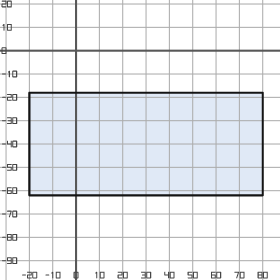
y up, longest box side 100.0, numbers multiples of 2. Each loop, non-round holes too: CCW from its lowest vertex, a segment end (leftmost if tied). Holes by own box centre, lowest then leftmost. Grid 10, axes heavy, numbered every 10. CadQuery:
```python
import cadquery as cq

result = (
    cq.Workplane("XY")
    .moveTo(-20.0, -62.0)
    .lineTo(80.0, -62.0)
    .lineTo(80.0, -18.0)
    .lineTo(-20.0, -18.0)
    .close()
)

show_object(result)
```